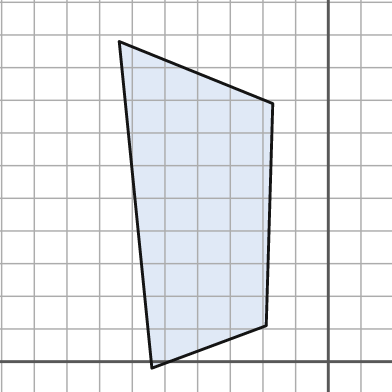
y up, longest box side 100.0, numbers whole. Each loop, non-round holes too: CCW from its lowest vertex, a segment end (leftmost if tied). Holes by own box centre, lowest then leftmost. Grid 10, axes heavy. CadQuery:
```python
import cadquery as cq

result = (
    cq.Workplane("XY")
    .moveTo(-54.0, -2.0)
    .lineTo(-19.0, 11.0)
    .lineTo(-17.0, 79.0)
    .lineTo(-64.0, 98.0)
    .close()
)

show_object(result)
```